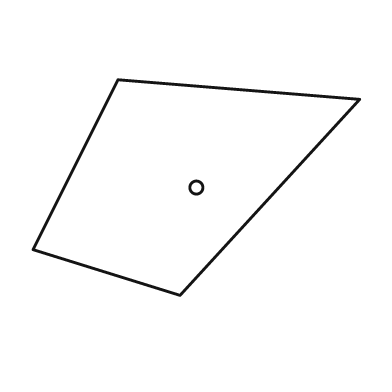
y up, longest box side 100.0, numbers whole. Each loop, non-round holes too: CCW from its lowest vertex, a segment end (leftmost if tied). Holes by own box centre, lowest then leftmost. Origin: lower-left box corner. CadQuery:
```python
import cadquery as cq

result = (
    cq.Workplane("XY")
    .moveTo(45.0, 0.0)
    .lineTo(100.0, 60.0)
    .lineTo(26.0, 66.0)
    .lineTo(0.0, 14.0)
    .close()
    .moveTo(50.0, 33.0)
    .circle(2.0)
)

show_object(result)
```